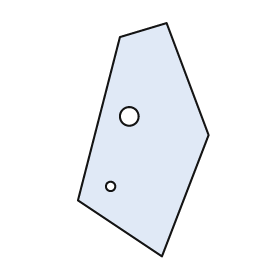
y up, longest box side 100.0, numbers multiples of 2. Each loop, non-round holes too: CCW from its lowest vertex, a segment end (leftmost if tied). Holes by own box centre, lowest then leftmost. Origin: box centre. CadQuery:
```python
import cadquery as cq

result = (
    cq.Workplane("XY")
    .moveTo(8.0, -50.0)
    .lineTo(28.0, 2.0)
    .lineTo(10.0, 50.0)
    .lineTo(-10.0, 44.0)
    .lineTo(-28.0, -26.0)
    .close()
    .moveTo(-14.0, -20.0)
    .circle(2.0)
    .moveTo(-6.0, 10.0)
    .circle(4.0)
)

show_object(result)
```